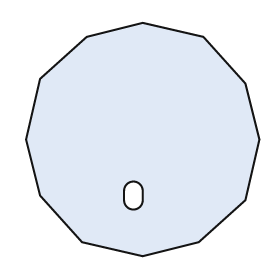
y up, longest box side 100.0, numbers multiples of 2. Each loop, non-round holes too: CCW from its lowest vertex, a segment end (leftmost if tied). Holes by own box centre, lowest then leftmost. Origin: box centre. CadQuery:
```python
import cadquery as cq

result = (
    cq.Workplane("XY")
    .moveTo(0.0, -50.0)
    .lineTo(24.0, -44.0)
    .lineTo(44.0, -26.0)
    .lineTo(50.0, 0.0)
    .lineTo(44.0, 24.0)
    .lineTo(26.0, 44.0)
    .lineTo(0.0, 50.0)
    .lineTo(-24.0, 44.0)
    .lineTo(-44.0, 26.0)
    .lineTo(-50.0, 0.0)
    .lineTo(-44.0, -24.0)
    .lineTo(-26.0, -44.0)
    .close()
    .moveTo(-8.0, -26.0)
    .threePointArc((-4.0, -30.0), (0.0, -26.0))
    .lineTo(0.0, -22.0)
    .threePointArc((-4.0, -18.0), (-8.0, -22.0))
    .close()
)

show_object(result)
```